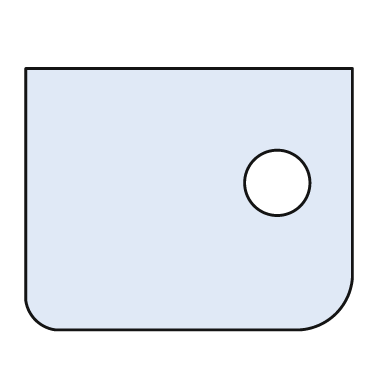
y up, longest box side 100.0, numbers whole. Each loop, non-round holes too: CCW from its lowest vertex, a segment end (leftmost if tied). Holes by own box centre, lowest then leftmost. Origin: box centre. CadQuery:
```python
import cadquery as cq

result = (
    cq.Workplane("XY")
    .moveTo(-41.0, -40.0)
    .lineTo(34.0, -40.0)
    .threePointArc((45.0, -35.0), (50.0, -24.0))
    .lineTo(50.0, 40.0)
    .lineTo(-50.0, 40.0)
    .lineTo(-50.0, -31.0)
    .threePointArc((-47.0, -37.0), (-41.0, -40.0))
    .close()
    .moveTo(27.0, 5.0)
    .circle(10.0)
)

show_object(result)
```